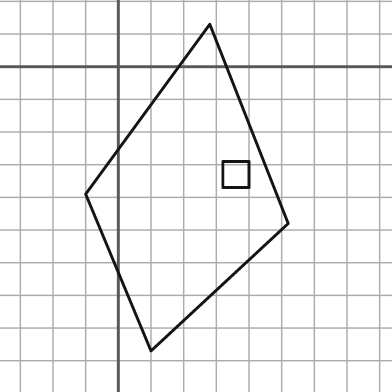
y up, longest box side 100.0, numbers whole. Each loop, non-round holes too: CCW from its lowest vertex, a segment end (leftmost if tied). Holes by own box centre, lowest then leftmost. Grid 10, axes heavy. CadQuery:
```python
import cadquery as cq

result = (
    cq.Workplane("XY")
    .moveTo(10.0, -87.0)
    .lineTo(52.0, -48.0)
    .lineTo(28.0, 13.0)
    .lineTo(-10.0, -39.0)
    .close()
    .moveTo(32.0, -37.0)
    .lineTo(40.0, -37.0)
    .lineTo(40.0, -29.0)
    .lineTo(32.0, -29.0)
    .close()
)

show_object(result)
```